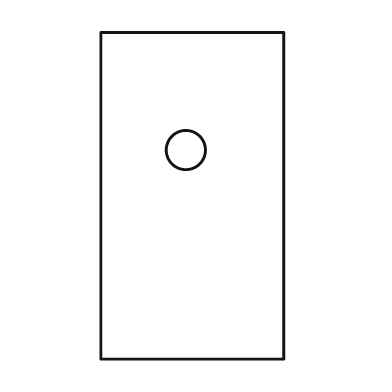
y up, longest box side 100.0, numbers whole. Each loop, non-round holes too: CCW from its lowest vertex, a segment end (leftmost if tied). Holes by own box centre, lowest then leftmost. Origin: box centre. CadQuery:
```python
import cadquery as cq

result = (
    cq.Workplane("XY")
    .moveTo(-28.0, -50.0)
    .lineTo(28.0, -50.0)
    .lineTo(28.0, 50.0)
    .lineTo(-28.0, 50.0)
    .close()
    .moveTo(-2.0, 14.0)
    .circle(6.0)
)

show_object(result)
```